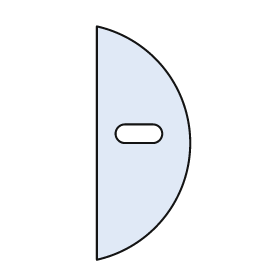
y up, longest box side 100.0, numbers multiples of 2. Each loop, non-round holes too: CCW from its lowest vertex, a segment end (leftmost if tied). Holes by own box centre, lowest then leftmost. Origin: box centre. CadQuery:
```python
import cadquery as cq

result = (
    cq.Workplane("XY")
    .moveTo(-20.0, -50.0)
    .threePointArc((20.0, 0.0), (-20.0, 50.0))
    .close()
    .moveTo(-8.0, 0.0)
    .lineTo(4.0, 0.0)
    .threePointArc((8.0, 4.0), (4.0, 8.0))
    .lineTo(-8.0, 8.0)
    .threePointArc((-12.0, 4.0), (-8.0, 0.0))
    .close()
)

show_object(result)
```